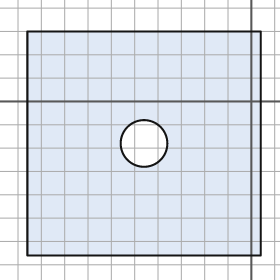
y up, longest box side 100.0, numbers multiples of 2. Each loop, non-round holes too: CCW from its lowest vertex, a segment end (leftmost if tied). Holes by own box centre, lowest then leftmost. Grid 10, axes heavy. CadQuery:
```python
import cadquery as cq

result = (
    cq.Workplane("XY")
    .moveTo(-96.0, -66.0)
    .lineTo(4.0, -66.0)
    .lineTo(4.0, 30.0)
    .lineTo(-96.0, 30.0)
    .close()
    .moveTo(-46.0, -18.0)
    .circle(10.0)
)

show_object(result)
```